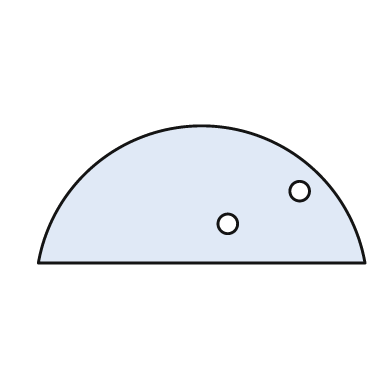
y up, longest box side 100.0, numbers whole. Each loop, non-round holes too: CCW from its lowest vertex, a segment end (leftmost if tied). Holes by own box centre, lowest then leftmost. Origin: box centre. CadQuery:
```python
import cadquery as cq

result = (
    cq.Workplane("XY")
    .moveTo(-50.0, -21.0)
    .lineTo(50.0, -21.0)
    .threePointArc((0.0, 21.0), (-50.0, -21.0))
    .close()
    .moveTo(8.0, -9.0)
    .circle(3.0)
    .moveTo(30.0, 1.0)
    .circle(3.0)
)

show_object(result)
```